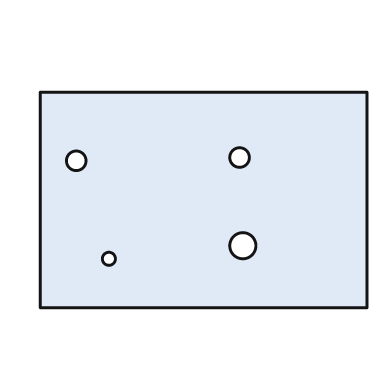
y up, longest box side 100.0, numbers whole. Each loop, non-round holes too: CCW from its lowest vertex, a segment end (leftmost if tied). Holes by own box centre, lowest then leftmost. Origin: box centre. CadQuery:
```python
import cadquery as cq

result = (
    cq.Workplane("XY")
    .moveTo(-50.0, -33.0)
    .lineTo(50.0, -33.0)
    .lineTo(50.0, 33.0)
    .lineTo(-50.0, 33.0)
    .close()
    .moveTo(-29.0, -18.0)
    .circle(2.0)
    .moveTo(12.0, -14.0)
    .circle(4.0)
    .moveTo(-39.0, 12.0)
    .circle(3.0)
    .moveTo(11.0, 13.0)
    .circle(3.0)
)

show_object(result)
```